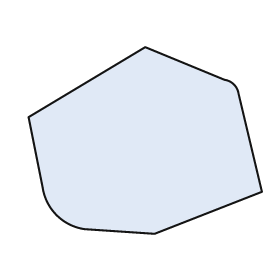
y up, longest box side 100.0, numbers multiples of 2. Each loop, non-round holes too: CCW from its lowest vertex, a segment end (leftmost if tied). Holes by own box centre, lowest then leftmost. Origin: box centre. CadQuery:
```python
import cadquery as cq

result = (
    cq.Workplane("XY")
    .moveTo(4.0, -40.0)
    .lineTo(50.0, -22.0)
    .lineTo(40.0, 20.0)
    .threePointArc((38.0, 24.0), (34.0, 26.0))
    .lineTo(0.0, 40.0)
    .lineTo(-50.0, 10.0)
    .lineTo(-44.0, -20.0)
    .threePointArc((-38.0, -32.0), (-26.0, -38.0))
    .close()
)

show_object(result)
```